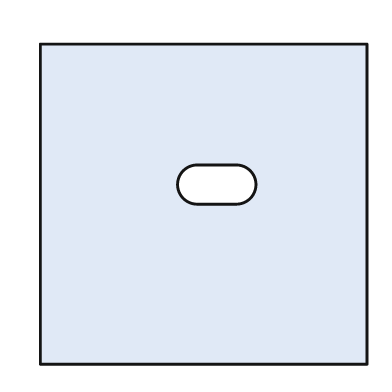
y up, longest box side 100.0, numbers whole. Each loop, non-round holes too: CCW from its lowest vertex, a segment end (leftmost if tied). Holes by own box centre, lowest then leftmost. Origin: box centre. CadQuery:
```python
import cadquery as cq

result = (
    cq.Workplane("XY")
    .moveTo(-50.0, -49.0)
    .lineTo(50.0, -49.0)
    .lineTo(50.0, 49.0)
    .lineTo(-50.0, 49.0)
    .close()
    .moveTo(-2.0, 0.0)
    .lineTo(10.0, 0.0)
    .threePointArc((16.0, 6.0), (10.0, 12.0))
    .lineTo(-2.0, 12.0)
    .threePointArc((-8.0, 6.0), (-2.0, 0.0))
    .close()
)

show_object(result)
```